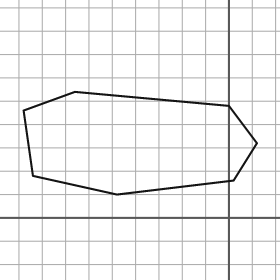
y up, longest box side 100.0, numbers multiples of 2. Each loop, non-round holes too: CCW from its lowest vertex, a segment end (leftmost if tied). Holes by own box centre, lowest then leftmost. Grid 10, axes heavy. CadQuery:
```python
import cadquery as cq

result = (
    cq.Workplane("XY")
    .moveTo(-48.0, 10.0)
    .lineTo(2.0, 16.0)
    .lineTo(12.0, 32.0)
    .lineTo(0.0, 48.0)
    .lineTo(-66.0, 54.0)
    .lineTo(-88.0, 46.0)
    .lineTo(-84.0, 18.0)
    .close()
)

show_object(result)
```